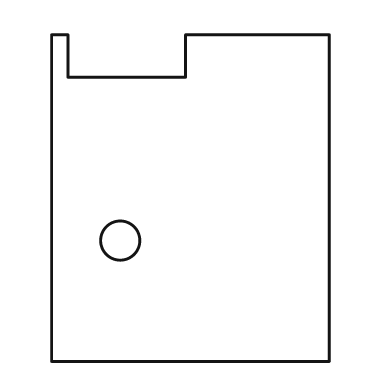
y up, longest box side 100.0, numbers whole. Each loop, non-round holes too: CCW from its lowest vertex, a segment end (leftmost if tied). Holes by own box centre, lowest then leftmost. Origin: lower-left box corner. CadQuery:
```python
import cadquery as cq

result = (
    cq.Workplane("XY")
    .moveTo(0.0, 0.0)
    .lineTo(85.0, 0.0)
    .lineTo(85.0, 100.0)
    .lineTo(41.0, 100.0)
    .lineTo(41.0, 87.0)
    .lineTo(5.0, 87.0)
    .lineTo(5.0, 100.0)
    .lineTo(0.0, 100.0)
    .close()
    .moveTo(21.0, 37.0)
    .circle(6.0)
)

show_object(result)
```